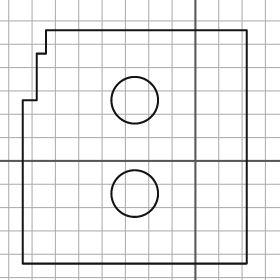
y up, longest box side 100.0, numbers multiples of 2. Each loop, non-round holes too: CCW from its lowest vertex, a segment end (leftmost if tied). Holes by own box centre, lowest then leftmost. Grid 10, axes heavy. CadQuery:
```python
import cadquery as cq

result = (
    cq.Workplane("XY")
    .moveTo(-74.0, -44.0)
    .lineTo(22.0, -44.0)
    .lineTo(22.0, 56.0)
    .lineTo(-64.0, 56.0)
    .lineTo(-64.0, 46.0)
    .lineTo(-68.0, 46.0)
    .lineTo(-68.0, 26.0)
    .lineTo(-74.0, 26.0)
    .close()
    .moveTo(-26.0, -14.0)
    .circle(10.0)
    .moveTo(-26.0, 26.0)
    .circle(10.0)
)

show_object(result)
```